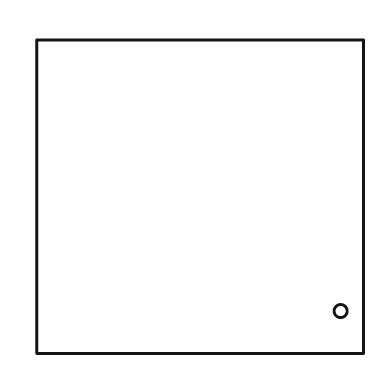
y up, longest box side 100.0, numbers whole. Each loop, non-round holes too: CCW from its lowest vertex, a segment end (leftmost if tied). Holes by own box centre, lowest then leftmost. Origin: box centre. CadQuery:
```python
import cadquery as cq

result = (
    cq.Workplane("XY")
    .moveTo(-50.0, -48.0)
    .lineTo(50.0, -48.0)
    .lineTo(50.0, 48.0)
    .lineTo(-50.0, 48.0)
    .close()
    .moveTo(43.0, -35.0)
    .circle(2.0)
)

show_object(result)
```